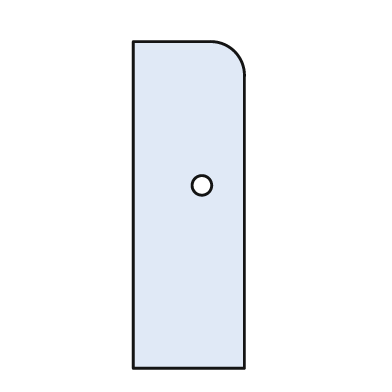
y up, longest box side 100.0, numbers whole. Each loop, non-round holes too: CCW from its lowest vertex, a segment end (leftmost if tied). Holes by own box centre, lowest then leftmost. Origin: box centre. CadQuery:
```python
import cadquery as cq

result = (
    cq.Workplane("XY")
    .moveTo(-17.0, -50.0)
    .lineTo(17.0, -50.0)
    .lineTo(17.0, 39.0)
    .threePointArc((14.0, 47.0), (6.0, 50.0))
    .lineTo(-17.0, 50.0)
    .close()
    .moveTo(4.0, 6.0)
    .circle(3.0)
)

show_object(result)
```